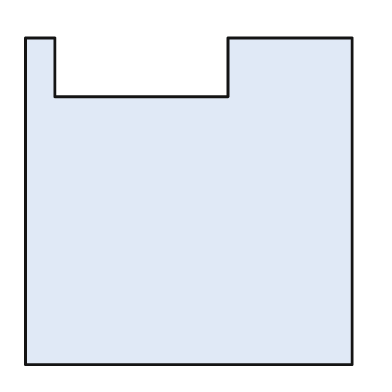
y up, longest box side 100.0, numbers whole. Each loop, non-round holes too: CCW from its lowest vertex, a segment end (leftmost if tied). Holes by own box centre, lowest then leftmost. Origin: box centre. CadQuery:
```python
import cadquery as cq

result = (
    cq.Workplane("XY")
    .moveTo(-50.0, -50.0)
    .lineTo(50.0, -50.0)
    .lineTo(50.0, 50.0)
    .lineTo(12.0, 50.0)
    .lineTo(12.0, 32.0)
    .lineTo(-41.0, 32.0)
    .lineTo(-41.0, 50.0)
    .lineTo(-50.0, 50.0)
    .close()
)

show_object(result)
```